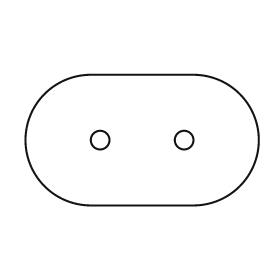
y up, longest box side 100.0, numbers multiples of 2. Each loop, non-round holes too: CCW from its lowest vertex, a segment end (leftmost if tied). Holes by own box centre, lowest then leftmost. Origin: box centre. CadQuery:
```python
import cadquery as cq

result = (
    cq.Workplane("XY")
    .moveTo(-22.0, -28.0)
    .lineTo(22.0, -28.0)
    .threePointArc((50.0, 0.0), (22.0, 28.0))
    .lineTo(-22.0, 28.0)
    .threePointArc((-50.0, 0.0), (-22.0, -28.0))
    .close()
    .moveTo(-18.0, 0.0)
    .circle(4.0)
    .moveTo(18.0, 0.0)
    .circle(4.0)
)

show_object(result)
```